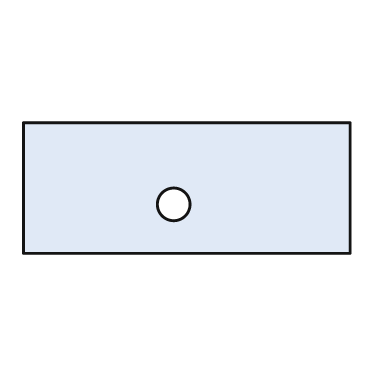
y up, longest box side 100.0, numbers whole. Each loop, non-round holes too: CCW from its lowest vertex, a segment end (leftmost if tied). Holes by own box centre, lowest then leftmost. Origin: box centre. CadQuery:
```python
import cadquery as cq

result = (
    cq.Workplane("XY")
    .moveTo(-50.0, -20.0)
    .lineTo(50.0, -20.0)
    .lineTo(50.0, 20.0)
    .lineTo(-50.0, 20.0)
    .close()
    .moveTo(-4.0, -5.0)
    .circle(5.0)
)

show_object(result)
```